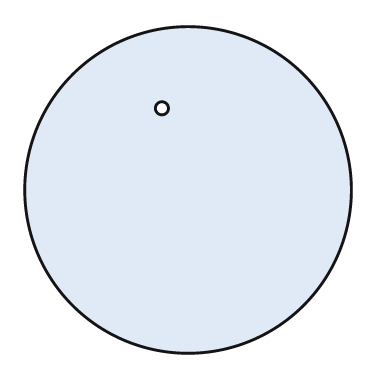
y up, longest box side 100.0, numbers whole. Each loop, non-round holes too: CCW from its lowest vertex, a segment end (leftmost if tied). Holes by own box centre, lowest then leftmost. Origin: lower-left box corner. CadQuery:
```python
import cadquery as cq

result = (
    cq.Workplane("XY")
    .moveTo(50.0, 50.0)
    .circle(50.0)
    .moveTo(42.0, 75.0)
    .circle(2.0)
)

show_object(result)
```